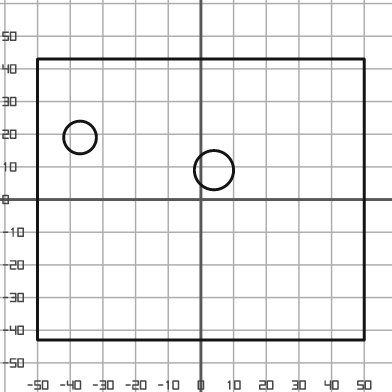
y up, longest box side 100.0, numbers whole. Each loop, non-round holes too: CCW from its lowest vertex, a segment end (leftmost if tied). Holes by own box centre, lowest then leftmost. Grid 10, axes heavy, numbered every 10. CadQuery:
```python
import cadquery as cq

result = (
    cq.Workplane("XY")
    .moveTo(-50.0, -43.0)
    .lineTo(50.0, -43.0)
    .lineTo(50.0, 43.0)
    .lineTo(-50.0, 43.0)
    .close()
    .moveTo(4.0, 9.0)
    .circle(6.0)
    .moveTo(-37.0, 19.0)
    .circle(5.0)
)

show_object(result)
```